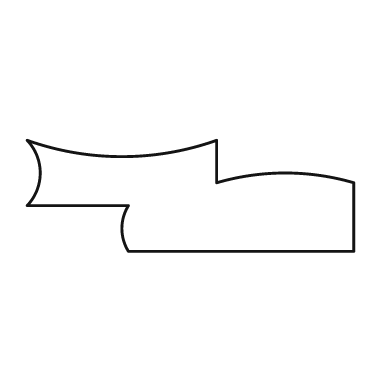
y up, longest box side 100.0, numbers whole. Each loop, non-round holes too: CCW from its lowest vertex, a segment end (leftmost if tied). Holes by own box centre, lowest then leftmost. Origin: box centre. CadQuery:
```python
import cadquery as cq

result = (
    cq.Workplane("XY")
    .moveTo(-19.0, -17.0)
    .lineTo(50.0, -17.0)
    .lineTo(50.0, 4.0)
    .threePointArc((29.0, 7.0), (8.0, 4.0))
    .lineTo(8.0, 17.0)
    .threePointArc((-21.0, 12.0), (-50.0, 17.0))
    .threePointArc((-46.0, 7.0), (-50.0, -3.0))
    .lineTo(-19.0, -3.0)
    .threePointArc((-21.0, -10.0), (-19.0, -17.0))
    .close()
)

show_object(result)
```